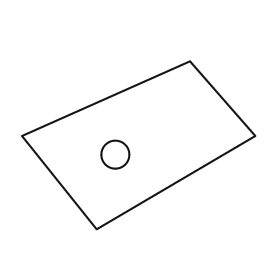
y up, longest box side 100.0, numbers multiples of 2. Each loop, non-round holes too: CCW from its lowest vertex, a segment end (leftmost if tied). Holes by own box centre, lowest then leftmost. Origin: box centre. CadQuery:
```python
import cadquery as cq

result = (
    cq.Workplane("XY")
    .moveTo(-18.0, -36.0)
    .lineTo(50.0, 4.0)
    .lineTo(22.0, 36.0)
    .lineTo(-50.0, 4.0)
    .close()
    .moveTo(-10.0, -4.0)
    .circle(6.0)
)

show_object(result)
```